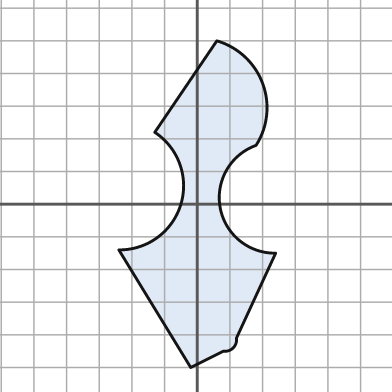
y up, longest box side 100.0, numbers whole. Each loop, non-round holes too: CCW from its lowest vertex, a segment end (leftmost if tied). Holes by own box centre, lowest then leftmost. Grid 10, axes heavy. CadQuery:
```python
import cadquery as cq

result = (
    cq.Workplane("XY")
    .moveTo(-2.0, -50.0)
    .lineTo(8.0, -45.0)
    .threePointArc((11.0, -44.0), (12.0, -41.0))
    .lineTo(24.0, -15.0)
    .threePointArc((7.0, -1.0), (18.0, 18.0))
    .threePointArc((20.0, 37.0), (6.0, 50.0))
    .lineTo(-13.0, 22.0)
    .threePointArc((-5.0, 0.0), (-24.0, -14.0))
    .close()
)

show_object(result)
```